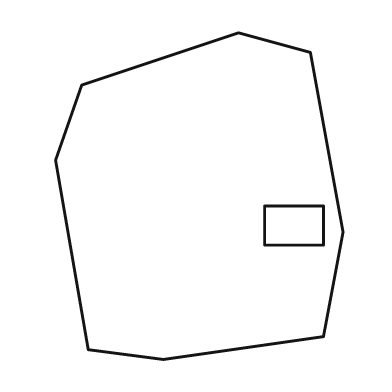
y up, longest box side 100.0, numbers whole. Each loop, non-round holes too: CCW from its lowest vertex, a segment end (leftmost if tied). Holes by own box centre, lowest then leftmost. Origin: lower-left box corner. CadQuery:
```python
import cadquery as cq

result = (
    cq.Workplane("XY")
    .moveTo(33.0, 0.0)
    .lineTo(82.0, 7.0)
    .lineTo(88.0, 39.0)
    .lineTo(78.0, 94.0)
    .lineTo(56.0, 100.0)
    .lineTo(8.0, 84.0)
    .lineTo(0.0, 61.0)
    .lineTo(10.0, 3.0)
    .close()
    .moveTo(64.0, 35.0)
    .lineTo(82.0, 35.0)
    .lineTo(82.0, 47.0)
    .lineTo(64.0, 47.0)
    .close()
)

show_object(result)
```